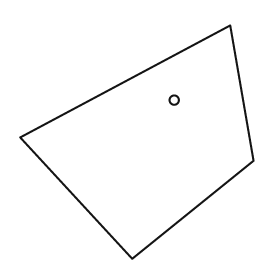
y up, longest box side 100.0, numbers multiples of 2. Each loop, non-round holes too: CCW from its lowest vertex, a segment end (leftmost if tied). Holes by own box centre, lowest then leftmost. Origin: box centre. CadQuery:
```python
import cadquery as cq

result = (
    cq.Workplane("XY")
    .moveTo(-2.0, -50.0)
    .lineTo(50.0, -8.0)
    .lineTo(40.0, 50.0)
    .lineTo(-50.0, 2.0)
    .close()
    .moveTo(16.0, 18.0)
    .circle(2.0)
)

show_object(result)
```